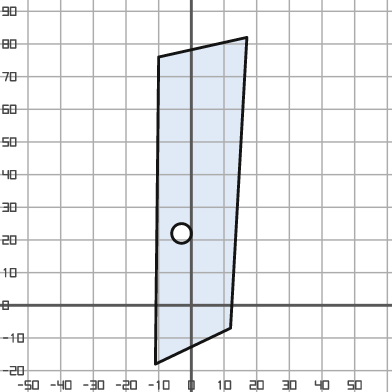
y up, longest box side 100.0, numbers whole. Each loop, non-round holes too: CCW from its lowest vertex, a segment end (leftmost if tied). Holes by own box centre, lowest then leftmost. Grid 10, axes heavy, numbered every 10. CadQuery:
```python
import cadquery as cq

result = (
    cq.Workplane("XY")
    .moveTo(-11.0, -18.0)
    .lineTo(12.0, -7.0)
    .lineTo(17.0, 82.0)
    .lineTo(-10.0, 76.0)
    .close()
    .moveTo(-3.0, 22.0)
    .circle(3.0)
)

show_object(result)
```